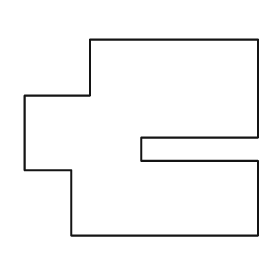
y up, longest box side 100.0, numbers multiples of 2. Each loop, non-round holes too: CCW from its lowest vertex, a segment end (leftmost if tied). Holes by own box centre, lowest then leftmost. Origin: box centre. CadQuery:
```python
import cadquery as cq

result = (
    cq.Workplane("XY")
    .moveTo(-30.0, -42.0)
    .lineTo(50.0, -42.0)
    .lineTo(50.0, -10.0)
    .lineTo(0.0, -10.0)
    .lineTo(0.0, 0.0)
    .lineTo(50.0, 0.0)
    .lineTo(50.0, 42.0)
    .lineTo(-22.0, 42.0)
    .lineTo(-22.0, 18.0)
    .lineTo(-50.0, 18.0)
    .lineTo(-50.0, -14.0)
    .lineTo(-30.0, -14.0)
    .close()
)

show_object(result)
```